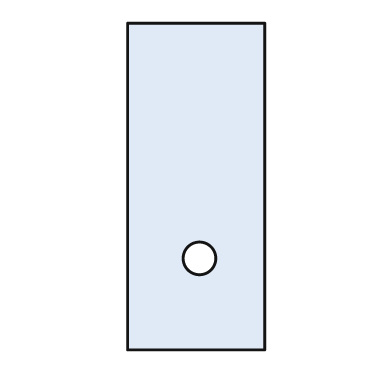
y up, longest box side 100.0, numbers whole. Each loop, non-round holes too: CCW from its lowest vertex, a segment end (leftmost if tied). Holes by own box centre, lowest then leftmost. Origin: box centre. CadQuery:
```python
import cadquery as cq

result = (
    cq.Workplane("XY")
    .moveTo(-21.0, -50.0)
    .lineTo(21.0, -50.0)
    .lineTo(21.0, 50.0)
    .lineTo(-21.0, 50.0)
    .close()
    .moveTo(1.0, -22.0)
    .circle(5.0)
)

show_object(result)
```